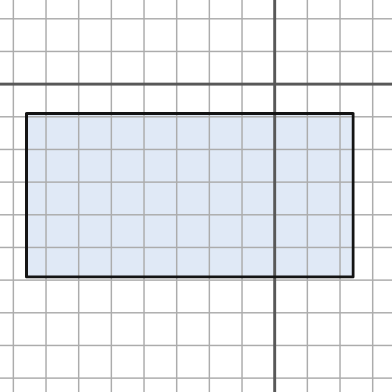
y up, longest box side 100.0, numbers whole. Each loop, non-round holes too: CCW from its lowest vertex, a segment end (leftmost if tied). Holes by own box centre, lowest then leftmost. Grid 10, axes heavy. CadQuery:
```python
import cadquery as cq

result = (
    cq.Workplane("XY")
    .moveTo(-76.0, -59.0)
    .lineTo(24.0, -59.0)
    .lineTo(24.0, -9.0)
    .lineTo(-76.0, -9.0)
    .close()
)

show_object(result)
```